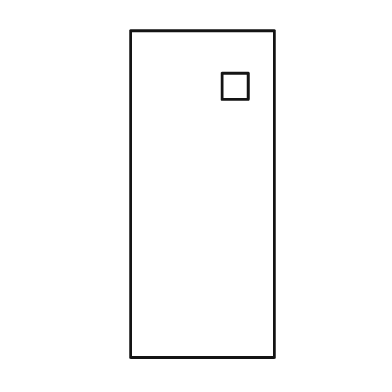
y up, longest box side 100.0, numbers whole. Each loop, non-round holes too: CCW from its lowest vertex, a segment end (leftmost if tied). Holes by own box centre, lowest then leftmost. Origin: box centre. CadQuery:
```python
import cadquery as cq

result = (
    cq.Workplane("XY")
    .moveTo(-22.0, -50.0)
    .lineTo(22.0, -50.0)
    .lineTo(22.0, 50.0)
    .lineTo(-22.0, 50.0)
    .close()
    .moveTo(6.0, 29.0)
    .lineTo(14.0, 29.0)
    .lineTo(14.0, 37.0)
    .lineTo(6.0, 37.0)
    .close()
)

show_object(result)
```